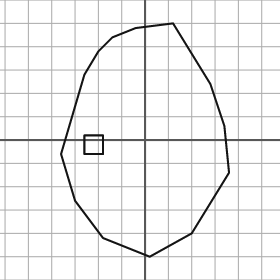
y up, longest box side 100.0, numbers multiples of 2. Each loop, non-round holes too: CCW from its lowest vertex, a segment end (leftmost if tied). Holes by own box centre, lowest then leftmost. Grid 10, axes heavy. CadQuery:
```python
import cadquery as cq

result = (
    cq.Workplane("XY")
    .moveTo(2.0, -50.0)
    .lineTo(20.0, -40.0)
    .lineTo(36.0, -14.0)
    .lineTo(34.0, 6.0)
    .lineTo(28.0, 24.0)
    .lineTo(12.0, 50.0)
    .lineTo(-4.0, 48.0)
    .lineTo(-14.0, 44.0)
    .lineTo(-20.0, 38.0)
    .lineTo(-26.0, 28.0)
    .lineTo(-36.0, -6.0)
    .lineTo(-30.0, -26.0)
    .lineTo(-18.0, -42.0)
    .close()
    .moveTo(-26.0, -6.0)
    .lineTo(-18.0, -6.0)
    .lineTo(-18.0, 2.0)
    .lineTo(-26.0, 2.0)
    .close()
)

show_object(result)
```